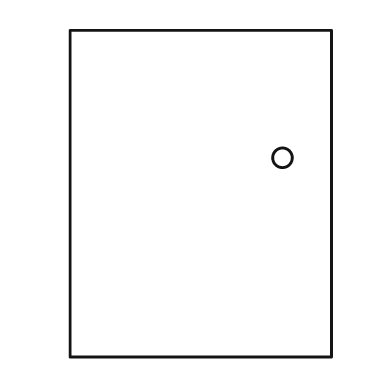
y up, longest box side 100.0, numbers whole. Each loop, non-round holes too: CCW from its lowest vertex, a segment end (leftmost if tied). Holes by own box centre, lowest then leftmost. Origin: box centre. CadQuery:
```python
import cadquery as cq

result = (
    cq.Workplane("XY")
    .moveTo(-40.0, -50.0)
    .lineTo(40.0, -50.0)
    .lineTo(40.0, 50.0)
    .lineTo(-40.0, 50.0)
    .close()
    .moveTo(25.0, 11.0)
    .circle(3.0)
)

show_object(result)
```